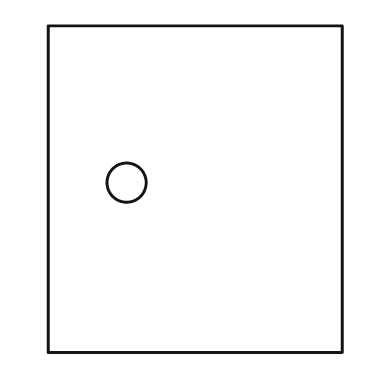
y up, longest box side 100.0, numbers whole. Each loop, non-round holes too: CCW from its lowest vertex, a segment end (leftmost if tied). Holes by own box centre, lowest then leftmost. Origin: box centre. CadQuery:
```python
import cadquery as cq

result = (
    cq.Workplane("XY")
    .moveTo(-45.0, -50.0)
    .lineTo(45.0, -50.0)
    .lineTo(45.0, 50.0)
    .lineTo(-45.0, 50.0)
    .close()
    .moveTo(-21.0, 2.0)
    .circle(6.0)
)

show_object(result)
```